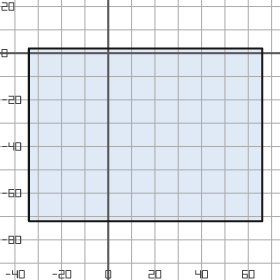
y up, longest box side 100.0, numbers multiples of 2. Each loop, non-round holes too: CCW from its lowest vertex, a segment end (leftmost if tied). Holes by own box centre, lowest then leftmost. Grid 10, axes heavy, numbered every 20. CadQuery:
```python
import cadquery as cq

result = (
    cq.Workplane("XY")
    .moveTo(-34.0, -72.0)
    .lineTo(66.0, -72.0)
    .lineTo(66.0, 2.0)
    .lineTo(-34.0, 2.0)
    .close()
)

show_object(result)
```